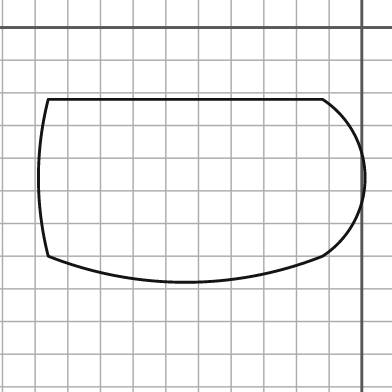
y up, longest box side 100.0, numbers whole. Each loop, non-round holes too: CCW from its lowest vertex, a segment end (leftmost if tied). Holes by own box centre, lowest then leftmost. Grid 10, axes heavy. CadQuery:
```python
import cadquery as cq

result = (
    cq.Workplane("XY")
    .moveTo(-96.0, -70.0)
    .threePointArc((-54.0, -78.0), (-12.0, -70.0))
    .threePointArc((1.0, -46.0), (-12.0, -22.0))
    .lineTo(-96.0, -22.0)
    .threePointArc((-99.0, -46.0), (-96.0, -70.0))
    .close()
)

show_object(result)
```